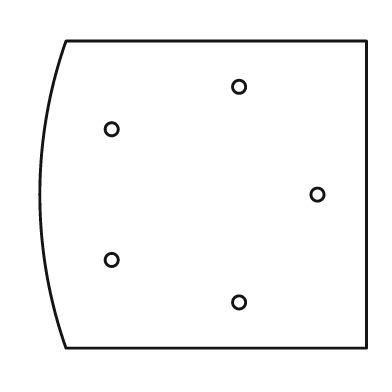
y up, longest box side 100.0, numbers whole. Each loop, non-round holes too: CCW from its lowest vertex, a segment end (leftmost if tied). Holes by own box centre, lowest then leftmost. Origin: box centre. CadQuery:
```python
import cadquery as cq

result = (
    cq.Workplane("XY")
    .moveTo(-42.0, -47.0)
    .lineTo(50.0, -47.0)
    .lineTo(50.0, 47.0)
    .lineTo(-42.0, 47.0)
    .threePointArc((-50.0, 0.0), (-42.0, -47.0))
    .close()
    .moveTo(11.0, -33.0)
    .circle(2.0)
    .moveTo(-28.0, -20.0)
    .circle(2.0)
    .moveTo(35.0, 0.0)
    .circle(2.0)
    .moveTo(-28.0, 20.0)
    .circle(2.0)
    .moveTo(11.0, 33.0)
    .circle(2.0)
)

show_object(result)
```